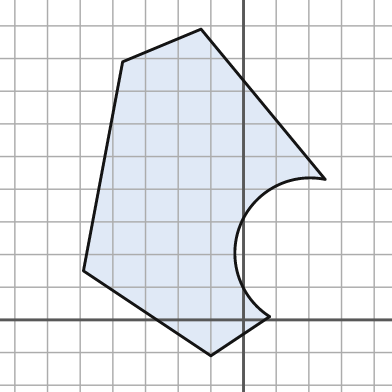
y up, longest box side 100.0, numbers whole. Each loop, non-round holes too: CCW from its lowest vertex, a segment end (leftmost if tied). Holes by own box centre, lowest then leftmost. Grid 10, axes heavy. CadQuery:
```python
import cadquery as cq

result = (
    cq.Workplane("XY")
    .moveTo(-10.0, -11.0)
    .lineTo(8.0, 1.0)
    .threePointArc((-1.0, 29.0), (25.0, 43.0))
    .lineTo(-13.0, 89.0)
    .lineTo(-37.0, 79.0)
    .lineTo(-49.0, 15.0)
    .close()
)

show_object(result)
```